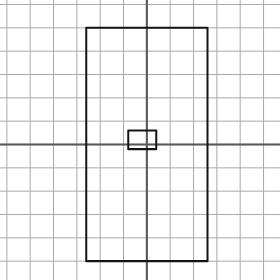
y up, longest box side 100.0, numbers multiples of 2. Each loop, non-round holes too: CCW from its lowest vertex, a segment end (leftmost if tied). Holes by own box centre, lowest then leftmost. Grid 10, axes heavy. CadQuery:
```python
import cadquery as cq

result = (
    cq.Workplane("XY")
    .moveTo(-26.0, -50.0)
    .lineTo(26.0, -50.0)
    .lineTo(26.0, 50.0)
    .lineTo(-26.0, 50.0)
    .close()
    .moveTo(-8.0, -2.0)
    .lineTo(4.0, -2.0)
    .lineTo(4.0, 6.0)
    .lineTo(-8.0, 6.0)
    .close()
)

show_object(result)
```